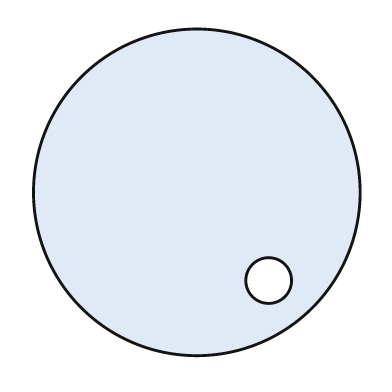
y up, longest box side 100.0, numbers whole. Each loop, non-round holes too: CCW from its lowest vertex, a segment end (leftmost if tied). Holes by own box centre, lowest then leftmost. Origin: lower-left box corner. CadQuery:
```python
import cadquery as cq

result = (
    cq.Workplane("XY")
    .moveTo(50.0, 50.0)
    .circle(50.0)
    .moveTo(72.0, 23.0)
    .circle(7.0)
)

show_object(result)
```